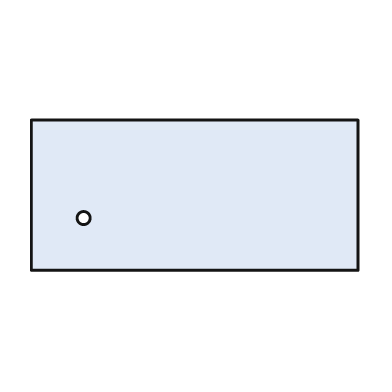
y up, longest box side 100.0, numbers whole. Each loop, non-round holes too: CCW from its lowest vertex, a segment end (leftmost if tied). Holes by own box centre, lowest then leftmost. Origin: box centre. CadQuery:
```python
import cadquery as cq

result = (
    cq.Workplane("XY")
    .moveTo(-50.0, -23.0)
    .lineTo(50.0, -23.0)
    .lineTo(50.0, 23.0)
    .lineTo(-50.0, 23.0)
    .close()
    .moveTo(-34.0, -7.0)
    .circle(2.0)
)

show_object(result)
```